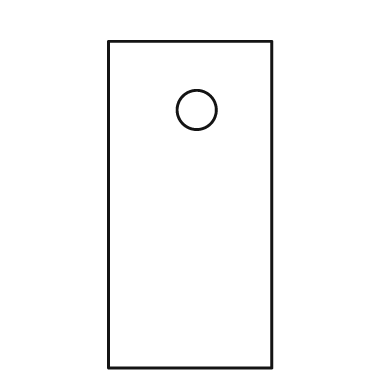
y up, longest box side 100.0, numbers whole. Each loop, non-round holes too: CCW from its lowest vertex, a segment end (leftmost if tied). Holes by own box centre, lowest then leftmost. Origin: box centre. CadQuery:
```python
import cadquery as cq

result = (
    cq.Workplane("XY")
    .moveTo(-25.0, -50.0)
    .lineTo(25.0, -50.0)
    .lineTo(25.0, 50.0)
    .lineTo(-25.0, 50.0)
    .close()
    .moveTo(2.0, 29.0)
    .circle(6.0)
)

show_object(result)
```